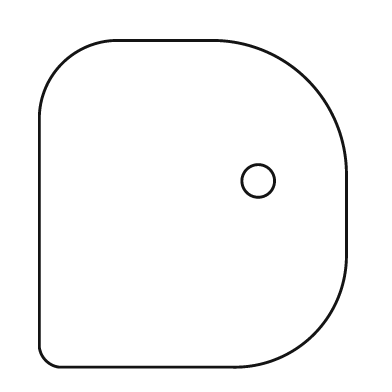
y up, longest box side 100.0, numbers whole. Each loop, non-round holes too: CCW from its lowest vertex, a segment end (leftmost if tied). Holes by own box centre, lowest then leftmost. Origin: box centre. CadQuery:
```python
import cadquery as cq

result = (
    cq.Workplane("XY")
    .moveTo(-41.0, -50.0)
    .lineTo(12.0, -50.0)
    .threePointArc((37.0, -40.0), (47.0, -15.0))
    .lineTo(47.0, 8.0)
    .threePointArc((35.0, 38.0), (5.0, 50.0))
    .lineTo(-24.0, 50.0)
    .threePointArc((-40.0, 43.0), (-47.0, 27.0))
    .lineTo(-47.0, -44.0)
    .threePointArc((-45.0, -48.0), (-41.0, -50.0))
    .close()
    .moveTo(20.0, 7.0)
    .circle(5.0)
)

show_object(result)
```